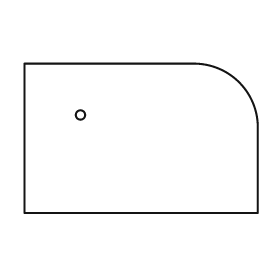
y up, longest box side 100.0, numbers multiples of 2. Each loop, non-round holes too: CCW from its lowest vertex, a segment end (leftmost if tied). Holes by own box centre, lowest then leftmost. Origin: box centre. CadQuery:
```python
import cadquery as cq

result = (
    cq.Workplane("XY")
    .moveTo(-50.0, -32.0)
    .lineTo(50.0, -32.0)
    .lineTo(50.0, 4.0)
    .threePointArc((42.0, 24.0), (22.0, 32.0))
    .lineTo(-50.0, 32.0)
    .close()
    .moveTo(-26.0, 10.0)
    .circle(2.0)
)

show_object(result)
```